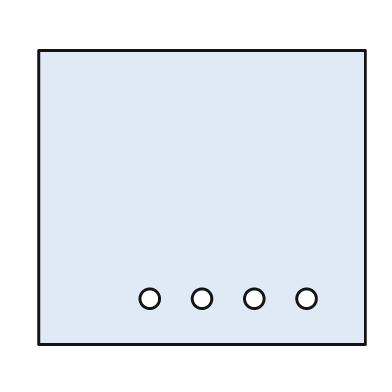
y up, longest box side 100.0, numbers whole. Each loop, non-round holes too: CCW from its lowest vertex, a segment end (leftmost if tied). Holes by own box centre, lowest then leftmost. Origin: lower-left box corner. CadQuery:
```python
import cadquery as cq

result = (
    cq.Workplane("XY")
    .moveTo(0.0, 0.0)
    .lineTo(100.0, 0.0)
    .lineTo(100.0, 90.0)
    .lineTo(0.0, 90.0)
    .close()
    .moveTo(34.0, 14.0)
    .circle(3.0)
    .moveTo(50.0, 14.0)
    .circle(3.0)
    .moveTo(66.0, 14.0)
    .circle(3.0)
    .moveTo(82.0, 14.0)
    .circle(3.0)
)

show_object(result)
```